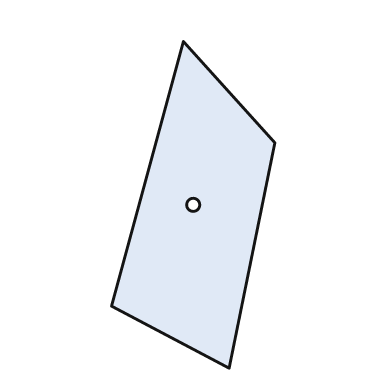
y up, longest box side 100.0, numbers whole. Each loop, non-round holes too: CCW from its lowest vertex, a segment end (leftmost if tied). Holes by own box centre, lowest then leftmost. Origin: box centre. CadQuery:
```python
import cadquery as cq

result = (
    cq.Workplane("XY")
    .moveTo(11.0, -50.0)
    .lineTo(25.0, 19.0)
    .lineTo(-3.0, 50.0)
    .lineTo(-25.0, -31.0)
    .close()
    .moveTo(0.0, 0.0)
    .circle(2.0)
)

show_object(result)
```